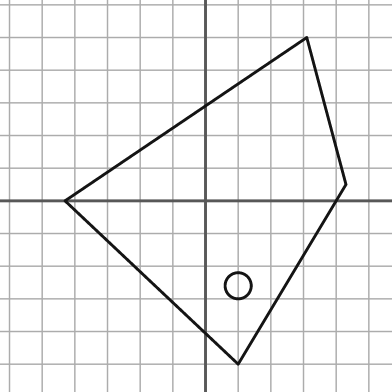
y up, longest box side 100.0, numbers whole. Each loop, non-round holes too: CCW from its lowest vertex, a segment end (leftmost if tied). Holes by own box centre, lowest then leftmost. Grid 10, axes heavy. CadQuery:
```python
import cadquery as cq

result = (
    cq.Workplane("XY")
    .moveTo(10.0, -50.0)
    .lineTo(43.0, 5.0)
    .lineTo(31.0, 50.0)
    .lineTo(-43.0, 0.0)
    .close()
    .moveTo(10.0, -26.0)
    .circle(4.0)
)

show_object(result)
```